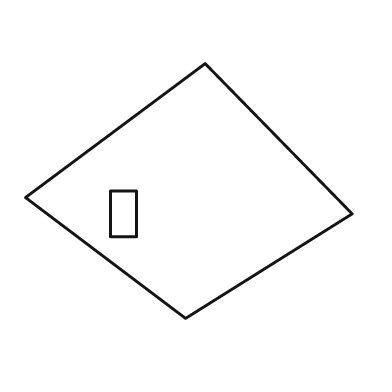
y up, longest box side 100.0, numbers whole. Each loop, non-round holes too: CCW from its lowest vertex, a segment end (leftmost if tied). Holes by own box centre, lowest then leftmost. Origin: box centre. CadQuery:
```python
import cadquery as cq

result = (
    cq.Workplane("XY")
    .moveTo(-1.0, -39.0)
    .lineTo(50.0, -7.0)
    .lineTo(5.0, 39.0)
    .lineTo(-50.0, -2.0)
    .close()
    .moveTo(-24.0, -14.0)
    .lineTo(-16.0, -14.0)
    .lineTo(-16.0, 0.0)
    .lineTo(-24.0, 0.0)
    .close()
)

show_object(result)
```